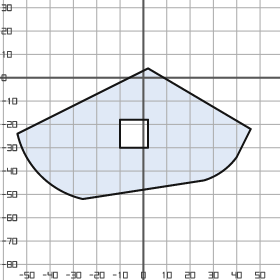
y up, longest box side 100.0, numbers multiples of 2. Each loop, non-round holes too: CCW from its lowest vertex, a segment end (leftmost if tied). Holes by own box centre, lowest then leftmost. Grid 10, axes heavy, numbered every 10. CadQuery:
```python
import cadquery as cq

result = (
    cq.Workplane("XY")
    .moveTo(-26.0, -52.0)
    .lineTo(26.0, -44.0)
    .threePointArc((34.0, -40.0), (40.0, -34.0))
    .lineTo(46.0, -22.0)
    .lineTo(2.0, 4.0)
    .lineTo(-54.0, -24.0)
    .threePointArc((-44.0, -42.0), (-26.0, -52.0))
    .close()
    .moveTo(-10.0, -30.0)
    .lineTo(2.0, -30.0)
    .lineTo(2.0, -18.0)
    .lineTo(-10.0, -18.0)
    .close()
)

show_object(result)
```